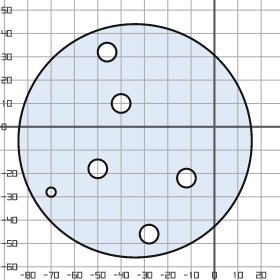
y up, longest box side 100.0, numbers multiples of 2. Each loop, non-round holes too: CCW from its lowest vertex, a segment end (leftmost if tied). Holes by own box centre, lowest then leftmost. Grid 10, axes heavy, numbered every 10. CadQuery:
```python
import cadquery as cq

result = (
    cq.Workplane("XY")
    .moveTo(-34.0, -6.0)
    .circle(50.0)
    .moveTo(-28.0, -46.0)
    .circle(4.0)
    .moveTo(-70.0, -28.0)
    .circle(2.0)
    .moveTo(-12.0, -22.0)
    .circle(4.0)
    .moveTo(-50.0, -18.0)
    .circle(4.0)
    .moveTo(-40.0, 10.0)
    .circle(4.0)
    .moveTo(-46.0, 32.0)
    .circle(4.0)
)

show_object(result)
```